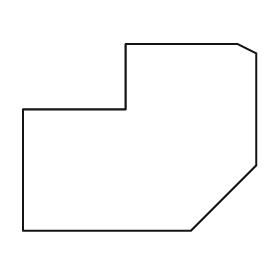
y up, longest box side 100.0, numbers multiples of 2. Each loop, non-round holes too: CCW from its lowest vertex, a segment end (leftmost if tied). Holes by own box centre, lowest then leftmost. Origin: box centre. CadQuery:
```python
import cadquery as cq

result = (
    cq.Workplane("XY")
    .moveTo(-50.0, -40.0)
    .lineTo(22.0, -40.0)
    .lineTo(50.0, -12.0)
    .lineTo(50.0, 36.0)
    .lineTo(42.0, 40.0)
    .lineTo(-6.0, 40.0)
    .lineTo(-6.0, 12.0)
    .lineTo(-50.0, 12.0)
    .close()
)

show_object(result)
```